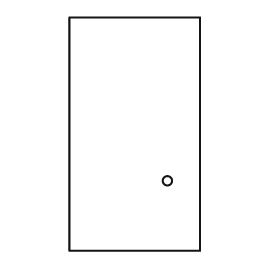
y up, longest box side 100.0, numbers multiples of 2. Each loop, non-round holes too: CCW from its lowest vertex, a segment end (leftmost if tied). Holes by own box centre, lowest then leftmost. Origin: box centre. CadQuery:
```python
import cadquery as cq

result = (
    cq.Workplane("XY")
    .moveTo(-28.0, -50.0)
    .lineTo(28.0, -50.0)
    .lineTo(28.0, 50.0)
    .lineTo(-28.0, 50.0)
    .close()
    .moveTo(14.0, -20.0)
    .circle(2.0)
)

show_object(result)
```